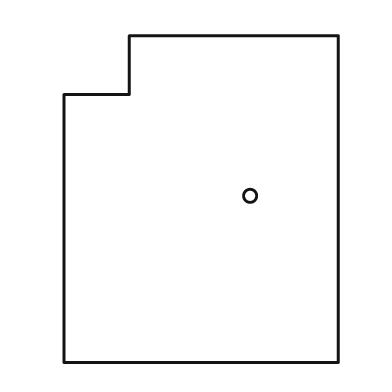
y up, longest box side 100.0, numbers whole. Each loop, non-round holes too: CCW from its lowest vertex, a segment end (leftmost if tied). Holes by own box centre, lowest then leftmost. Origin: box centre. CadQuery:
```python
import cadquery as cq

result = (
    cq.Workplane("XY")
    .moveTo(-42.0, -50.0)
    .lineTo(42.0, -50.0)
    .lineTo(42.0, 50.0)
    .lineTo(-22.0, 50.0)
    .lineTo(-22.0, 32.0)
    .lineTo(-42.0, 32.0)
    .close()
    .moveTo(15.0, 1.0)
    .circle(2.0)
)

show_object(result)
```